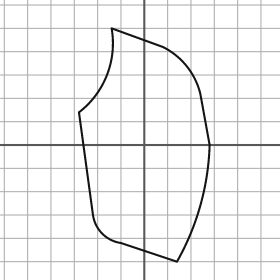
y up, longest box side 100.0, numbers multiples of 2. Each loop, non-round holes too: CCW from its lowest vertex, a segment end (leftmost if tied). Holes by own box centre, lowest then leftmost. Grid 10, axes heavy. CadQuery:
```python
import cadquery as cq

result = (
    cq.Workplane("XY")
    .moveTo(14.0, -50.0)
    .threePointArc((24.0, -26.0), (28.0, 0.0))
    .lineTo(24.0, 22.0)
    .threePointArc((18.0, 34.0), (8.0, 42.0))
    .lineTo(-14.0, 50.0)
    .threePointArc((-16.0, 30.0), (-28.0, 14.0))
    .lineTo(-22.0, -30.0)
    .threePointArc((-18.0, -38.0), (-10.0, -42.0))
    .close()
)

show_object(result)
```